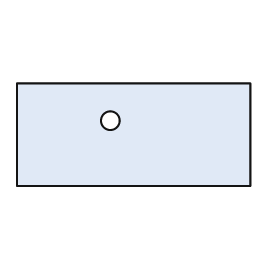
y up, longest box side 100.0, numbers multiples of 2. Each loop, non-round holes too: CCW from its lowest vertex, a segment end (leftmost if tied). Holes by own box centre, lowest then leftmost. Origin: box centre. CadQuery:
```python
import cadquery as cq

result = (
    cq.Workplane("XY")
    .moveTo(-50.0, -22.0)
    .lineTo(50.0, -22.0)
    .lineTo(50.0, 22.0)
    .lineTo(-50.0, 22.0)
    .close()
    .moveTo(-10.0, 6.0)
    .circle(4.0)
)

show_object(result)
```